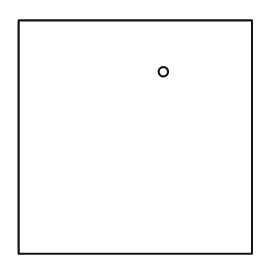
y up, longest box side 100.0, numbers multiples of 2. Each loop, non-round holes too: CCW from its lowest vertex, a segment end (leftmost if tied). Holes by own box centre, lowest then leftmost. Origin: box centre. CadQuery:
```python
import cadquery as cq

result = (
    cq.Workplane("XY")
    .moveTo(-50.0, -50.0)
    .lineTo(50.0, -50.0)
    .lineTo(50.0, 50.0)
    .lineTo(-50.0, 50.0)
    .close()
    .moveTo(12.0, 28.0)
    .circle(2.0)
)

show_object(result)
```